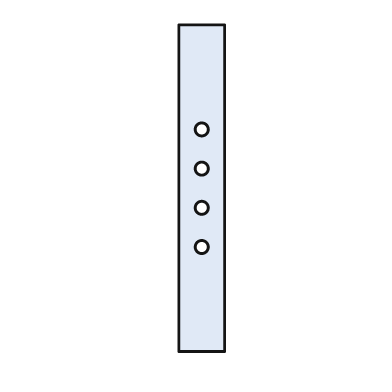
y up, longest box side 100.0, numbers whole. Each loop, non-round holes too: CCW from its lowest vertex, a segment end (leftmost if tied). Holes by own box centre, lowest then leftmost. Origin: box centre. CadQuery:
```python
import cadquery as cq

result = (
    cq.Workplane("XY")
    .moveTo(-7.0, -50.0)
    .lineTo(7.0, -50.0)
    .lineTo(7.0, 50.0)
    .lineTo(-7.0, 50.0)
    .close()
    .moveTo(0.0, -18.0)
    .circle(2.0)
    .moveTo(0.0, -6.0)
    .circle(2.0)
    .moveTo(0.0, 6.0)
    .circle(2.0)
    .moveTo(0.0, 18.0)
    .circle(2.0)
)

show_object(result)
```